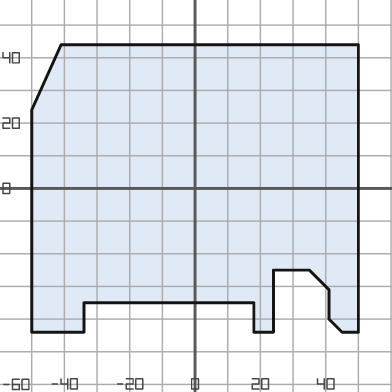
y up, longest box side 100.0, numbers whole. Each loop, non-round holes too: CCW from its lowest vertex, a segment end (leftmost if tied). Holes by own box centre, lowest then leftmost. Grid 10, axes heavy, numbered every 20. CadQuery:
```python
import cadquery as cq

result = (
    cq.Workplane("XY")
    .moveTo(-50.0, -44.0)
    .lineTo(-34.0, -44.0)
    .lineTo(-34.0, -35.0)
    .lineTo(18.0, -35.0)
    .lineTo(18.0, -44.0)
    .lineTo(24.0, -44.0)
    .lineTo(24.0, -25.0)
    .lineTo(35.0, -25.0)
    .lineTo(41.0, -31.0)
    .lineTo(41.0, -40.0)
    .lineTo(45.0, -44.0)
    .lineTo(50.0, -44.0)
    .lineTo(50.0, 44.0)
    .lineTo(-41.0, 44.0)
    .lineTo(-50.0, 24.0)
    .close()
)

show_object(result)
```